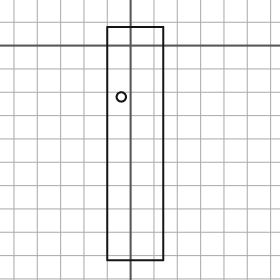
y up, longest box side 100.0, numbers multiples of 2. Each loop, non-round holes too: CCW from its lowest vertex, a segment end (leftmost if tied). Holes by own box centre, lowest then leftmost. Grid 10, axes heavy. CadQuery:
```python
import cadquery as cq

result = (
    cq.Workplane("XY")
    .moveTo(-10.0, -92.0)
    .lineTo(14.0, -92.0)
    .lineTo(14.0, 8.0)
    .lineTo(-10.0, 8.0)
    .close()
    .moveTo(-4.0, -22.0)
    .circle(2.0)
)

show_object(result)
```